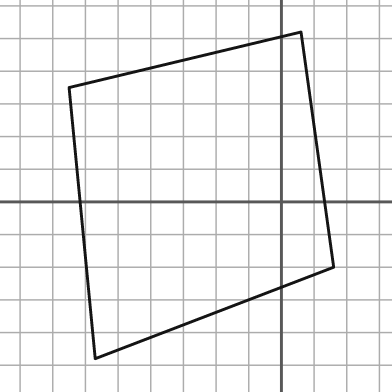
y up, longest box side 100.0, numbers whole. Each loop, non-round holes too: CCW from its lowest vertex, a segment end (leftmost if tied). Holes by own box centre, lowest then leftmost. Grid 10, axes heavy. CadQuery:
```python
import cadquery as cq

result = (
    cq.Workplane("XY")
    .moveTo(-57.0, -48.0)
    .lineTo(16.0, -20.0)
    .lineTo(6.0, 52.0)
    .lineTo(-65.0, 35.0)
    .close()
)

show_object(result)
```